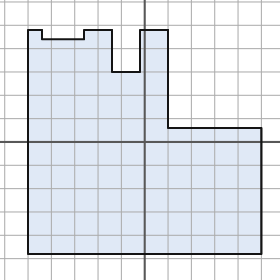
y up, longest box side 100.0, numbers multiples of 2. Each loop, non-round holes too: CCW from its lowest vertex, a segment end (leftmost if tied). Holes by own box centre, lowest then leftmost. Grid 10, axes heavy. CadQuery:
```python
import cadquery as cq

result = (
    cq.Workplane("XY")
    .moveTo(-50.0, -48.0)
    .lineTo(50.0, -48.0)
    .lineTo(50.0, 6.0)
    .lineTo(10.0, 6.0)
    .lineTo(10.0, 48.0)
    .lineTo(-2.0, 48.0)
    .lineTo(-2.0, 30.0)
    .lineTo(-14.0, 30.0)
    .lineTo(-14.0, 48.0)
    .lineTo(-26.0, 48.0)
    .lineTo(-26.0, 44.0)
    .lineTo(-44.0, 44.0)
    .lineTo(-44.0, 48.0)
    .lineTo(-50.0, 48.0)
    .close()
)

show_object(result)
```